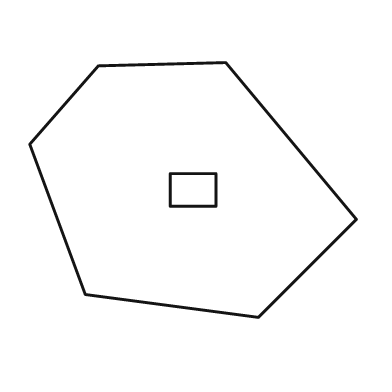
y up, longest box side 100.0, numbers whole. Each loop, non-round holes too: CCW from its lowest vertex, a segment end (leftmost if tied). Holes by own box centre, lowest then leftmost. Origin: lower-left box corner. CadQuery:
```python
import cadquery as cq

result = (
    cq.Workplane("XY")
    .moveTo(70.0, 0.0)
    .lineTo(100.0, 30.0)
    .lineTo(60.0, 78.0)
    .lineTo(21.0, 77.0)
    .lineTo(0.0, 53.0)
    .lineTo(17.0, 7.0)
    .close()
    .moveTo(43.0, 34.0)
    .lineTo(57.0, 34.0)
    .lineTo(57.0, 44.0)
    .lineTo(43.0, 44.0)
    .close()
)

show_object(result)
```